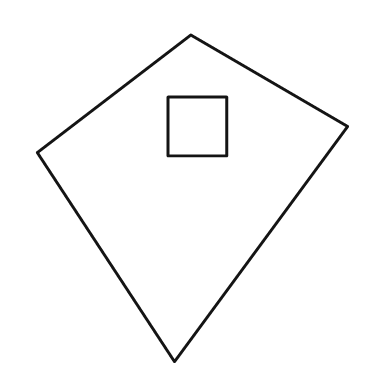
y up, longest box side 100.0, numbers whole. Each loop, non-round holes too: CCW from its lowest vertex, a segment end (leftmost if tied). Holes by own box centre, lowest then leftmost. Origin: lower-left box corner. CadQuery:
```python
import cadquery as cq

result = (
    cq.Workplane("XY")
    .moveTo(42.0, 0.0)
    .lineTo(95.0, 72.0)
    .lineTo(47.0, 100.0)
    .lineTo(0.0, 64.0)
    .close()
    .moveTo(40.0, 63.0)
    .lineTo(58.0, 63.0)
    .lineTo(58.0, 81.0)
    .lineTo(40.0, 81.0)
    .close()
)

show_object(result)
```